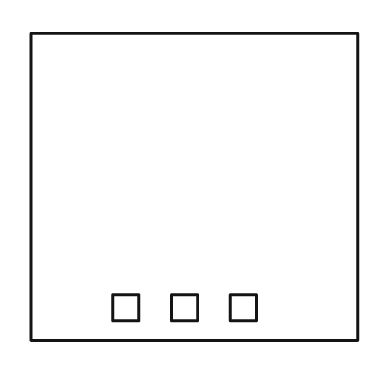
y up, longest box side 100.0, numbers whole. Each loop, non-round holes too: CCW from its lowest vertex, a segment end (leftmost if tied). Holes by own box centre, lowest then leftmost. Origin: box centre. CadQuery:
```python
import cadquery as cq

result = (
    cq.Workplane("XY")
    .moveTo(-50.0, -47.0)
    .lineTo(50.0, -47.0)
    .lineTo(50.0, 47.0)
    .lineTo(-50.0, 47.0)
    .close()
    .moveTo(-25.0, -41.0)
    .lineTo(-17.0, -41.0)
    .lineTo(-17.0, -33.0)
    .lineTo(-25.0, -33.0)
    .close()
    .moveTo(-7.0, -41.0)
    .lineTo(1.0, -41.0)
    .lineTo(1.0, -33.0)
    .lineTo(-7.0, -33.0)
    .close()
    .moveTo(11.0, -41.0)
    .lineTo(19.0, -41.0)
    .lineTo(19.0, -33.0)
    .lineTo(11.0, -33.0)
    .close()
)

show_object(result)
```